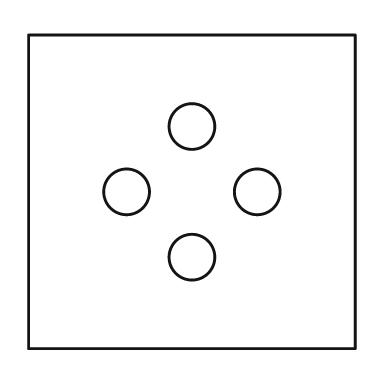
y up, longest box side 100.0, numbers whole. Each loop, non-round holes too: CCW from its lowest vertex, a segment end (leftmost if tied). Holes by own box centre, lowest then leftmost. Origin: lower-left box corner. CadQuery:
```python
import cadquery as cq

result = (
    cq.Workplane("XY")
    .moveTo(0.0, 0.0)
    .lineTo(100.0, 0.0)
    .lineTo(100.0, 96.0)
    .lineTo(0.0, 96.0)
    .close()
    .moveTo(50.0, 28.0)
    .circle(7.0)
    .moveTo(30.0, 48.0)
    .circle(7.0)
    .moveTo(70.0, 48.0)
    .circle(7.0)
    .moveTo(50.0, 68.0)
    .circle(7.0)
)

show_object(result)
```